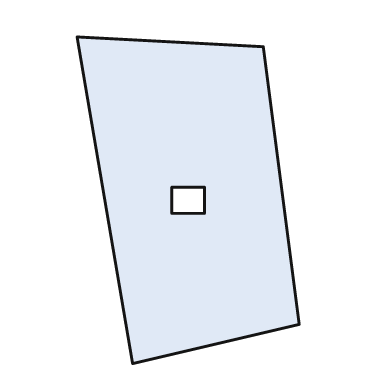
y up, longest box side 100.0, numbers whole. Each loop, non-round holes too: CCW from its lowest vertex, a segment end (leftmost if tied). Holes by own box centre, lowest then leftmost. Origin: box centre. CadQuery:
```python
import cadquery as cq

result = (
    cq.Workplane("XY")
    .moveTo(-17.0, -50.0)
    .lineTo(34.0, -38.0)
    .lineTo(23.0, 47.0)
    .lineTo(-34.0, 50.0)
    .close()
    .moveTo(-5.0, -4.0)
    .lineTo(5.0, -4.0)
    .lineTo(5.0, 4.0)
    .lineTo(-5.0, 4.0)
    .close()
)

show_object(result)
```